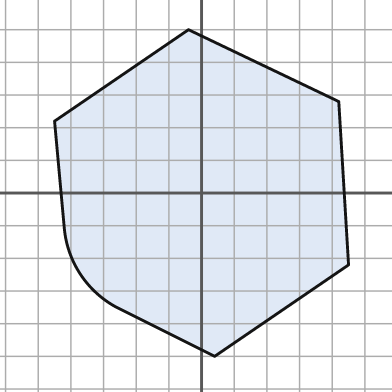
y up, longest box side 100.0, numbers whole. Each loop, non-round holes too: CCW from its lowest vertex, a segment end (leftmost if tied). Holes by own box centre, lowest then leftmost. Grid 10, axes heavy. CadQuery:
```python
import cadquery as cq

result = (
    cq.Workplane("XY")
    .moveTo(4.0, -50.0)
    .lineTo(45.0, -22.0)
    .lineTo(42.0, 28.0)
    .lineTo(-4.0, 50.0)
    .lineTo(-45.0, 22.0)
    .lineTo(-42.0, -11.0)
    .threePointArc((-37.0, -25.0), (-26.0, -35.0))
    .close()
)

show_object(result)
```